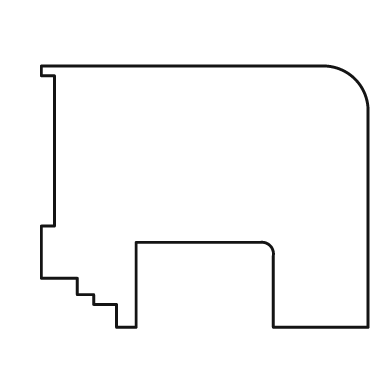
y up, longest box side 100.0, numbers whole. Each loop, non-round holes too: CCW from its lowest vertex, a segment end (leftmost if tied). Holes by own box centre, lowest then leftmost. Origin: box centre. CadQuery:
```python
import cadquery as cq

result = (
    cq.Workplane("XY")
    .moveTo(-27.0, -40.0)
    .lineTo(-21.0, -40.0)
    .lineTo(-21.0, -14.0)
    .lineTo(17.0, -14.0)
    .threePointArc((20.0, -15.0), (21.0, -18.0))
    .lineTo(21.0, -40.0)
    .lineTo(50.0, -40.0)
    .lineTo(50.0, 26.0)
    .threePointArc((46.0, 36.0), (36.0, 40.0))
    .lineTo(-50.0, 40.0)
    .lineTo(-50.0, 37.0)
    .lineTo(-46.0, 37.0)
    .lineTo(-46.0, -9.0)
    .lineTo(-50.0, -9.0)
    .lineTo(-50.0, -25.0)
    .lineTo(-39.0, -25.0)
    .lineTo(-39.0, -30.0)
    .lineTo(-34.0, -30.0)
    .lineTo(-34.0, -33.0)
    .lineTo(-27.0, -33.0)
    .close()
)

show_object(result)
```